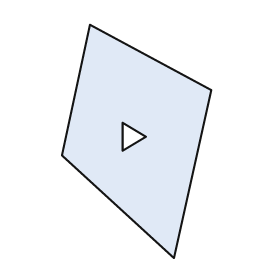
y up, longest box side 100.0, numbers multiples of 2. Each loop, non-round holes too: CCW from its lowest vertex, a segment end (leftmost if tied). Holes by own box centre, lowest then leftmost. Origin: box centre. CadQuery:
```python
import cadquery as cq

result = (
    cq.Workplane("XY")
    .moveTo(16.0, -50.0)
    .lineTo(32.0, 22.0)
    .lineTo(-20.0, 50.0)
    .lineTo(-32.0, -6.0)
    .close()
    .moveTo(-6.0, -4.0)
    .lineTo(4.0, 2.0)
    .lineTo(-6.0, 8.0)
    .close()
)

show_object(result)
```